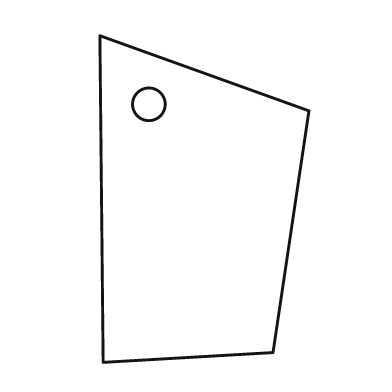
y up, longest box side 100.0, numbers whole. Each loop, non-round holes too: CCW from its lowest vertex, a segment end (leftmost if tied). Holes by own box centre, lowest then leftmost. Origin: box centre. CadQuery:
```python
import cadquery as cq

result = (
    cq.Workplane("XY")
    .moveTo(-31.0, -50.0)
    .lineTo(21.0, -47.0)
    .lineTo(32.0, 27.0)
    .lineTo(-32.0, 50.0)
    .close()
    .moveTo(-17.0, 29.0)
    .circle(5.0)
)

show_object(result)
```